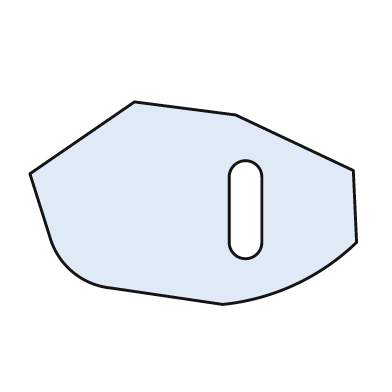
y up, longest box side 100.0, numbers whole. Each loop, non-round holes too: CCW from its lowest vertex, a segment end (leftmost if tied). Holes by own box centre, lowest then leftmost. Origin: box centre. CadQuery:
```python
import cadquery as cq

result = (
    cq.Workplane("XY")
    .moveTo(9.0, -31.0)
    .threePointArc((31.0, -25.0), (50.0, -12.0))
    .lineTo(49.0, 10.0)
    .lineTo(13.0, 27.0)
    .lineTo(-18.0, 31.0)
    .lineTo(-50.0, 9.0)
    .lineTo(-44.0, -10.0)
    .threePointArc((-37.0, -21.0), (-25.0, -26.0))
    .close()
    .moveTo(11.0, -12.0)
    .threePointArc((16.0, -17.0), (21.0, -12.0))
    .lineTo(21.0, 8.0)
    .threePointArc((16.0, 13.0), (11.0, 8.0))
    .close()
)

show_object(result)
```